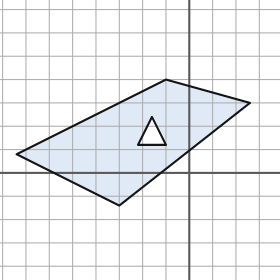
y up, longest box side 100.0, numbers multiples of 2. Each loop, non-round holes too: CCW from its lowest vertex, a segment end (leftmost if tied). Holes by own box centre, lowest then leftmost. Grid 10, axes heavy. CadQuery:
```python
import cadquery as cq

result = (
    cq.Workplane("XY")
    .moveTo(-30.0, -14.0)
    .lineTo(26.0, 30.0)
    .lineTo(-10.0, 40.0)
    .lineTo(-74.0, 8.0)
    .close()
    .moveTo(-22.0, 12.0)
    .lineTo(-10.0, 12.0)
    .lineTo(-16.0, 24.0)
    .close()
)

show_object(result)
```